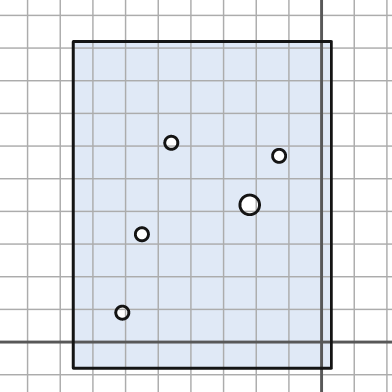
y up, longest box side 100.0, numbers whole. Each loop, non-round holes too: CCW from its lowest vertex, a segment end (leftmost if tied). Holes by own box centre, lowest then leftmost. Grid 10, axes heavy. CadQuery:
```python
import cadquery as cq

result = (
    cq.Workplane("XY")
    .moveTo(-76.0, -8.0)
    .lineTo(3.0, -8.0)
    .lineTo(3.0, 92.0)
    .lineTo(-76.0, 92.0)
    .close()
    .moveTo(-61.0, 9.0)
    .circle(2.0)
    .moveTo(-55.0, 33.0)
    .circle(2.0)
    .moveTo(-22.0, 42.0)
    .circle(3.0)
    .moveTo(-13.0, 57.0)
    .circle(2.0)
    .moveTo(-46.0, 61.0)
    .circle(2.0)
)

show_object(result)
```